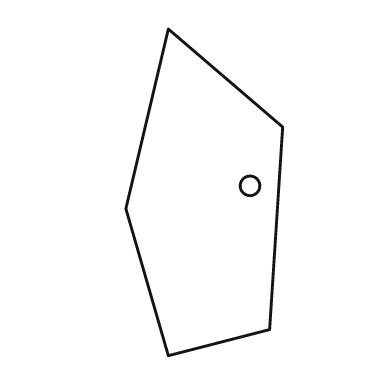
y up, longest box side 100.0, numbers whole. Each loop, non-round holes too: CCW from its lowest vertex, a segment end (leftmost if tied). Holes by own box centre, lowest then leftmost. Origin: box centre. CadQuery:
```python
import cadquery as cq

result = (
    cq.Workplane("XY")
    .moveTo(-11.0, -50.0)
    .lineTo(20.0, -42.0)
    .lineTo(24.0, 20.0)
    .lineTo(-11.0, 50.0)
    .lineTo(-24.0, -5.0)
    .close()
    .moveTo(14.0, 2.0)
    .circle(3.0)
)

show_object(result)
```